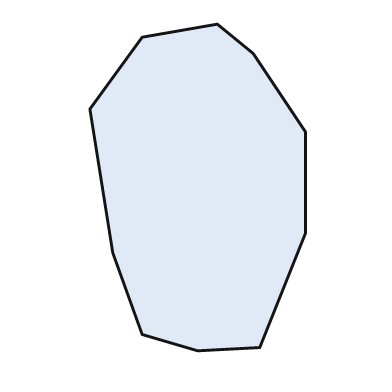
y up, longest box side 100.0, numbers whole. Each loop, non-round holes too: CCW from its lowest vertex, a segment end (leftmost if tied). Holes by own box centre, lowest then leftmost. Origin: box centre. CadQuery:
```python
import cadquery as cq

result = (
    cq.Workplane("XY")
    .moveTo(0.0, -50.0)
    .lineTo(19.0, -49.0)
    .lineTo(33.0, -14.0)
    .lineTo(33.0, 17.0)
    .lineTo(17.0, 41.0)
    .lineTo(6.0, 50.0)
    .lineTo(-17.0, 46.0)
    .lineTo(-33.0, 24.0)
    .lineTo(-26.0, -20.0)
    .lineTo(-17.0, -45.0)
    .close()
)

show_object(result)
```